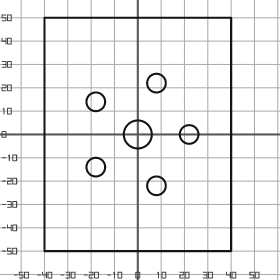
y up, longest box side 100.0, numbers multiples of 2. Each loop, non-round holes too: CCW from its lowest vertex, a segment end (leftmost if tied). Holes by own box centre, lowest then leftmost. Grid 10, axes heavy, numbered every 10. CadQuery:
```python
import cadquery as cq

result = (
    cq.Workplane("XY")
    .moveTo(-40.0, -50.0)
    .lineTo(40.0, -50.0)
    .lineTo(40.0, 50.0)
    .lineTo(-40.0, 50.0)
    .close()
    .moveTo(8.0, -22.0)
    .circle(4.0)
    .moveTo(-18.0, -14.0)
    .circle(4.0)
    .moveTo(0.0, 0.0)
    .circle(6.0)
    .moveTo(22.0, 0.0)
    .circle(4.0)
    .moveTo(-18.0, 14.0)
    .circle(4.0)
    .moveTo(8.0, 22.0)
    .circle(4.0)
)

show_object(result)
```